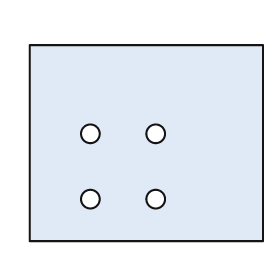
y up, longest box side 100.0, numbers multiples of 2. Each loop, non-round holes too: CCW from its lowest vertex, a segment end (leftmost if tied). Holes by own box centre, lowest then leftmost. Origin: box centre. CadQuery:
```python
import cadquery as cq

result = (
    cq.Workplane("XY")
    .moveTo(-50.0, -42.0)
    .lineTo(50.0, -42.0)
    .lineTo(50.0, 42.0)
    .lineTo(-50.0, 42.0)
    .close()
    .moveTo(-24.0, -24.0)
    .circle(4.0)
    .moveTo(4.0, -24.0)
    .circle(4.0)
    .moveTo(-24.0, 4.0)
    .circle(4.0)
    .moveTo(4.0, 4.0)
    .circle(4.0)
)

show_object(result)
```